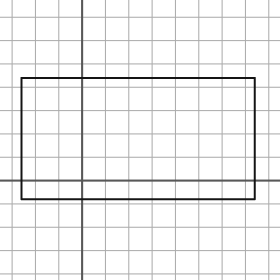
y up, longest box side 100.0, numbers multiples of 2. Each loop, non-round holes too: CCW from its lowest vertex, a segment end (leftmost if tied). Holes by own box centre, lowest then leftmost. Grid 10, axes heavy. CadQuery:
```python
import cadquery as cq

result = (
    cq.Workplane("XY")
    .moveTo(-26.0, -8.0)
    .lineTo(74.0, -8.0)
    .lineTo(74.0, 44.0)
    .lineTo(-26.0, 44.0)
    .close()
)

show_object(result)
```